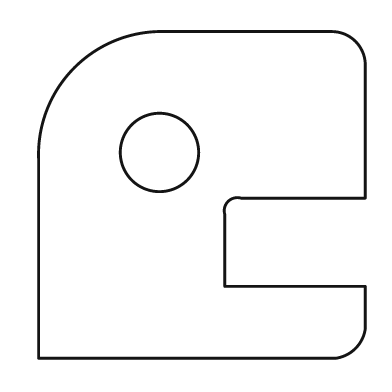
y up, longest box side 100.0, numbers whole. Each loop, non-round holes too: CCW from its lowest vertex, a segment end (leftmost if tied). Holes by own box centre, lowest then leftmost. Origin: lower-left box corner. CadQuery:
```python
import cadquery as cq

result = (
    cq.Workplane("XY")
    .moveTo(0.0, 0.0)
    .lineTo(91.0, 0.0)
    .threePointArc((97.0, 3.0), (100.0, 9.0))
    .lineTo(100.0, 22.0)
    .lineTo(57.0, 22.0)
    .lineTo(57.0, 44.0)
    .threePointArc((58.0, 48.0), (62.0, 49.0))
    .lineTo(100.0, 49.0)
    .lineTo(100.0, 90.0)
    .threePointArc((97.0, 97.0), (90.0, 100.0))
    .lineTo(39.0, 100.0)
    .threePointArc((11.0, 89.0), (0.0, 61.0))
    .close()
    .moveTo(37.0, 63.0)
    .circle(12.0)
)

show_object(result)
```